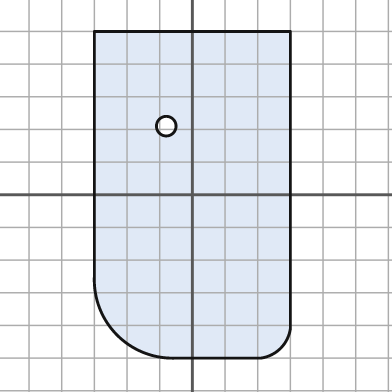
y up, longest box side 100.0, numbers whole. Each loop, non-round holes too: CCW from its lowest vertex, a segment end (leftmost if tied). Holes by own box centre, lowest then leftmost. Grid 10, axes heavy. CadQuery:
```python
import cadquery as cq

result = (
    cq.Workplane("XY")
    .moveTo(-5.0, -50.0)
    .lineTo(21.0, -50.0)
    .threePointArc((27.0, -47.0), (30.0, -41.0))
    .lineTo(30.0, 50.0)
    .lineTo(-30.0, 50.0)
    .lineTo(-30.0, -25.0)
    .threePointArc((-23.0, -43.0), (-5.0, -50.0))
    .close()
    .moveTo(-8.0, 21.0)
    .circle(3.0)
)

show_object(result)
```